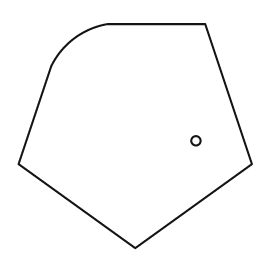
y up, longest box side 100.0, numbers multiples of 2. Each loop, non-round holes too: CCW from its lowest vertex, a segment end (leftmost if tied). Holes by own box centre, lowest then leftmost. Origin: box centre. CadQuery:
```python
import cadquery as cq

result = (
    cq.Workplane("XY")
    .moveTo(0.0, -48.0)
    .lineTo(50.0, -12.0)
    .lineTo(30.0, 48.0)
    .lineTo(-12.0, 48.0)
    .threePointArc((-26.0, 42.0), (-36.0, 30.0))
    .lineTo(-50.0, -12.0)
    .close()
    .moveTo(26.0, -2.0)
    .circle(2.0)
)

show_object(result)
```